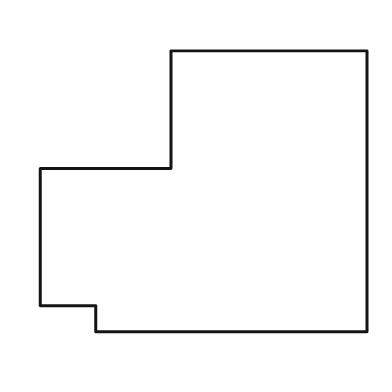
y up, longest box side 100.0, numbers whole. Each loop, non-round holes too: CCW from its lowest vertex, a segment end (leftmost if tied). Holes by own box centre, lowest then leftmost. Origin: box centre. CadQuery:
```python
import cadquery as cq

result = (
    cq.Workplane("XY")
    .moveTo(-33.0, -43.0)
    .lineTo(50.0, -43.0)
    .lineTo(50.0, 43.0)
    .lineTo(-10.0, 43.0)
    .lineTo(-10.0, 7.0)
    .lineTo(-50.0, 7.0)
    .lineTo(-50.0, -35.0)
    .lineTo(-33.0, -35.0)
    .close()
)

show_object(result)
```